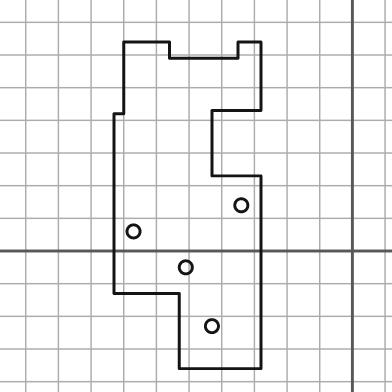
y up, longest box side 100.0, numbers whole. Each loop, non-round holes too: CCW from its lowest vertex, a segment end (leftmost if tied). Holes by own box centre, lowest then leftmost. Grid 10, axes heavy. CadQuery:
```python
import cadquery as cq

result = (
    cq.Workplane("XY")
    .moveTo(-53.0, -36.0)
    .lineTo(-28.0, -36.0)
    .lineTo(-28.0, 23.0)
    .lineTo(-43.0, 23.0)
    .lineTo(-43.0, 43.0)
    .lineTo(-28.0, 43.0)
    .lineTo(-28.0, 64.0)
    .lineTo(-35.0, 64.0)
    .lineTo(-35.0, 59.0)
    .lineTo(-56.0, 59.0)
    .lineTo(-56.0, 64.0)
    .lineTo(-70.0, 64.0)
    .lineTo(-70.0, 42.0)
    .lineTo(-73.0, 42.0)
    .lineTo(-73.0, -13.0)
    .lineTo(-53.0, -13.0)
    .close()
    .moveTo(-43.0, -23.0)
    .circle(2.0)
    .moveTo(-51.0, -5.0)
    .circle(2.0)
    .moveTo(-67.0, 6.0)
    .circle(2.0)
    .moveTo(-34.0, 14.0)
    .circle(2.0)
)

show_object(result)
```